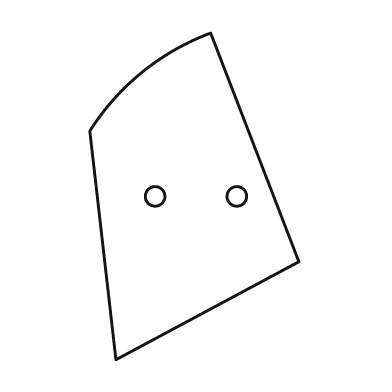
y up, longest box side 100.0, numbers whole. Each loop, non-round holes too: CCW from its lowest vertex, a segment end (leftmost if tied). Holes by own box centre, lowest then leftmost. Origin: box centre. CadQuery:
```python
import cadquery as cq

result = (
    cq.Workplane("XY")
    .moveTo(-24.0, -50.0)
    .lineTo(32.0, -20.0)
    .lineTo(5.0, 50.0)
    .threePointArc((-16.0, 38.0), (-32.0, 20.0))
    .close()
    .moveTo(-12.0, 0.0)
    .circle(3.0)
    .moveTo(13.0, 0.0)
    .circle(3.0)
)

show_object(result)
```